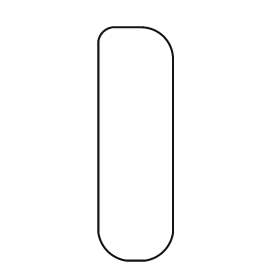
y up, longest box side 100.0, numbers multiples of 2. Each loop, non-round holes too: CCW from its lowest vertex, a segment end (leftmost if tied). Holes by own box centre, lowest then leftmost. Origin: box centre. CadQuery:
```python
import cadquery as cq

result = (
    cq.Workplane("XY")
    .moveTo(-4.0, -50.0)
    .lineTo(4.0, -50.0)
    .threePointArc((12.0, -46.0), (16.0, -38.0))
    .lineTo(16.0, 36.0)
    .threePointArc((12.0, 46.0), (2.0, 50.0))
    .lineTo(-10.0, 50.0)
    .threePointArc((-14.0, 48.0), (-16.0, 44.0))
    .lineTo(-16.0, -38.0)
    .threePointArc((-12.0, -46.0), (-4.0, -50.0))
    .close()
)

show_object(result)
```